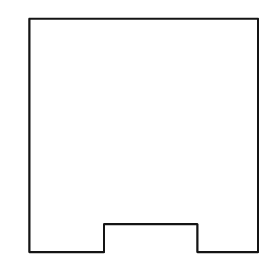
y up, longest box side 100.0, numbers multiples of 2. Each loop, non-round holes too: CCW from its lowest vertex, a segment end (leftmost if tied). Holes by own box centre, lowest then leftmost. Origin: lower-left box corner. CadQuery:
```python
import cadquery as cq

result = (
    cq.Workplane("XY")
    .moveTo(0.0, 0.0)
    .lineTo(32.0, 0.0)
    .lineTo(32.0, 12.0)
    .lineTo(72.0, 12.0)
    .lineTo(72.0, 0.0)
    .lineTo(98.0, 0.0)
    .lineTo(98.0, 100.0)
    .lineTo(0.0, 100.0)
    .close()
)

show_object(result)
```